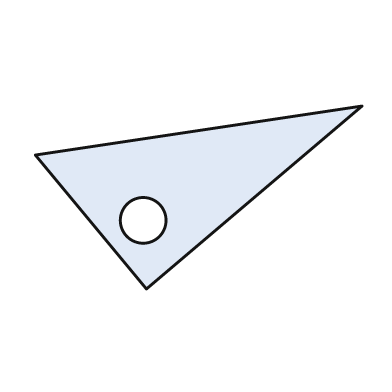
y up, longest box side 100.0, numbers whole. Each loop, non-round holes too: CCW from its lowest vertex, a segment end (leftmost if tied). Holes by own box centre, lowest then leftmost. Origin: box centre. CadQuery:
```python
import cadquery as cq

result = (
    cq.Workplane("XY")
    .moveTo(-16.0, -28.0)
    .lineTo(50.0, 28.0)
    .lineTo(-50.0, 13.0)
    .close()
    .moveTo(-17.0, -7.0)
    .circle(7.0)
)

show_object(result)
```